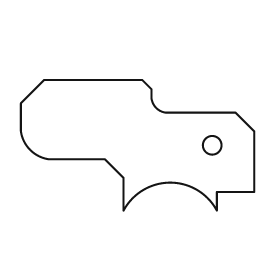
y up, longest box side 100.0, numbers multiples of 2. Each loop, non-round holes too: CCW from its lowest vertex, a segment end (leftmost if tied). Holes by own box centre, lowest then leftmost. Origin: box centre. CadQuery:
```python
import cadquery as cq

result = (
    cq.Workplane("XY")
    .moveTo(-6.0, -28.0)
    .threePointArc((14.0, -16.0), (34.0, -28.0))
    .lineTo(34.0, -20.0)
    .lineTo(50.0, -20.0)
    .lineTo(50.0, 6.0)
    .lineTo(42.0, 14.0)
    .lineTo(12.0, 14.0)
    .threePointArc((8.0, 16.0), (6.0, 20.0))
    .lineTo(6.0, 24.0)
    .lineTo(2.0, 28.0)
    .lineTo(-40.0, 28.0)
    .lineTo(-50.0, 18.0)
    .lineTo(-50.0, 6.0)
    .threePointArc((-46.0, -2.0), (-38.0, -6.0))
    .lineTo(-14.0, -6.0)
    .lineTo(-6.0, -14.0)
    .close()
    .moveTo(32.0, 0.0)
    .circle(4.0)
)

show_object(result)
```